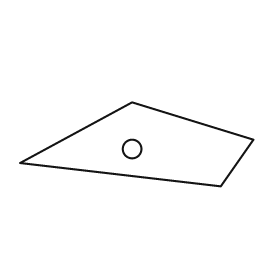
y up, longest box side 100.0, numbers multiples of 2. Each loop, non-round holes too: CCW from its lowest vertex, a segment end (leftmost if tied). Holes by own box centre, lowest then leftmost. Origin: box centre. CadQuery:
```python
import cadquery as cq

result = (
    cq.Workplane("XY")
    .moveTo(36.0, -18.0)
    .lineTo(50.0, 2.0)
    .lineTo(-2.0, 18.0)
    .lineTo(-50.0, -8.0)
    .close()
    .moveTo(-2.0, -2.0)
    .circle(4.0)
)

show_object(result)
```